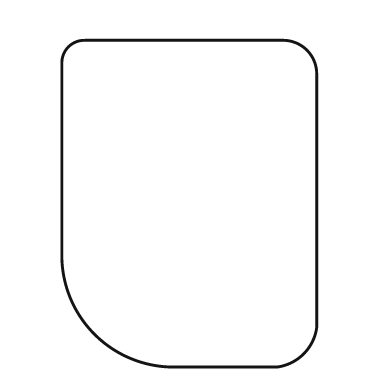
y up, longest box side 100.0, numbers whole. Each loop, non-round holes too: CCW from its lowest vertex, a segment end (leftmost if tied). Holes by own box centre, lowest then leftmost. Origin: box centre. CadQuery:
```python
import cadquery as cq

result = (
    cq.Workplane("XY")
    .moveTo(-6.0, -50.0)
    .lineTo(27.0, -50.0)
    .threePointArc((35.0, -46.0), (39.0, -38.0))
    .lineTo(39.0, 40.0)
    .threePointArc((36.0, 47.0), (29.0, 50.0))
    .lineTo(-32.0, 50.0)
    .threePointArc((-37.0, 48.0), (-39.0, 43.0))
    .lineTo(-39.0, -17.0)
    .threePointArc((-29.0, -40.0), (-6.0, -50.0))
    .close()
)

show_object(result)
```